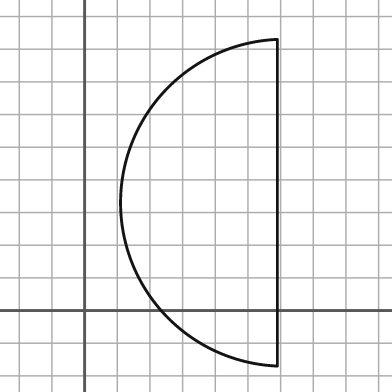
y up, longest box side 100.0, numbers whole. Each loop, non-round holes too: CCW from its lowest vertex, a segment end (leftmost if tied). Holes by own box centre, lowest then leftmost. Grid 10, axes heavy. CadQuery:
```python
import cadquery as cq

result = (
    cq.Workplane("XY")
    .moveTo(59.0, -17.0)
    .lineTo(59.0, 83.0)
    .threePointArc((11.0, 33.0), (59.0, -17.0))
    .close()
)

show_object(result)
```